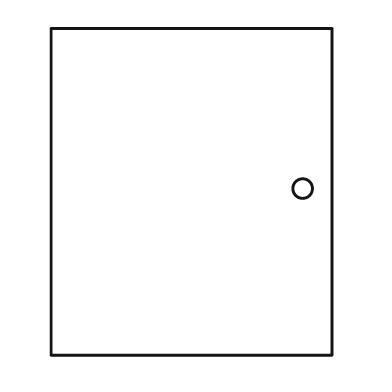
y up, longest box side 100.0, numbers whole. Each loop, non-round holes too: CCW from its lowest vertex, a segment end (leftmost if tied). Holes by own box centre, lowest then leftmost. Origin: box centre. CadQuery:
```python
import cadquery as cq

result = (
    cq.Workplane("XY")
    .moveTo(-43.0, -50.0)
    .lineTo(43.0, -50.0)
    .lineTo(43.0, 50.0)
    .lineTo(-43.0, 50.0)
    .close()
    .moveTo(34.0, 1.0)
    .circle(3.0)
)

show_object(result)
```